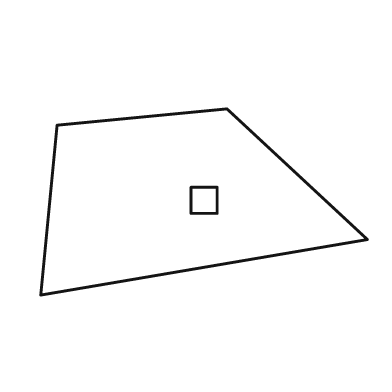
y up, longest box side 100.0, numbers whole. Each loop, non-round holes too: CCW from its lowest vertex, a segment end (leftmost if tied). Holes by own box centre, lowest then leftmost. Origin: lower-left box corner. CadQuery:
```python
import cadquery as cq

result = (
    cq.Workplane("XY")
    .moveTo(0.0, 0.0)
    .lineTo(100.0, 17.0)
    .lineTo(57.0, 57.0)
    .lineTo(5.0, 52.0)
    .close()
    .moveTo(46.0, 25.0)
    .lineTo(54.0, 25.0)
    .lineTo(54.0, 33.0)
    .lineTo(46.0, 33.0)
    .close()
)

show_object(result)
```